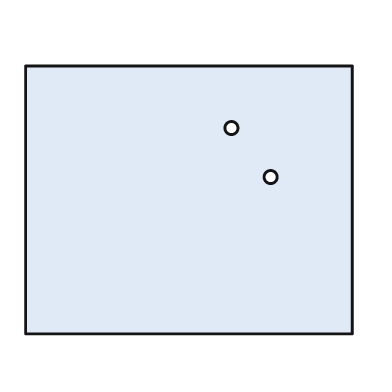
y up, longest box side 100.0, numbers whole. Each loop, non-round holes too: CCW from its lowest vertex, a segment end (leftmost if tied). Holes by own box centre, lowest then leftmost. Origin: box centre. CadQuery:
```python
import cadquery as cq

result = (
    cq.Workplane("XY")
    .moveTo(-50.0, -41.0)
    .lineTo(50.0, -41.0)
    .lineTo(50.0, 41.0)
    .lineTo(-50.0, 41.0)
    .close()
    .moveTo(25.0, 7.0)
    .circle(2.0)
    .moveTo(13.0, 22.0)
    .circle(2.0)
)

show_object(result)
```